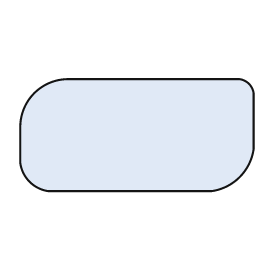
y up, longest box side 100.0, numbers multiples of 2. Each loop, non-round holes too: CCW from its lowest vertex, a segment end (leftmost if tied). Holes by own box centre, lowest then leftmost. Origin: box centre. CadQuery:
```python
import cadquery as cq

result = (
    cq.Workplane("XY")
    .moveTo(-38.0, -24.0)
    .lineTo(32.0, -24.0)
    .threePointArc((44.0, -18.0), (50.0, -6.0))
    .lineTo(50.0, 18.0)
    .threePointArc((48.0, 22.0), (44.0, 24.0))
    .lineTo(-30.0, 24.0)
    .threePointArc((-44.0, 18.0), (-50.0, 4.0))
    .lineTo(-50.0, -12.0)
    .threePointArc((-46.0, -20.0), (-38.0, -24.0))
    .close()
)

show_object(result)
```